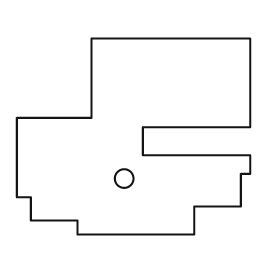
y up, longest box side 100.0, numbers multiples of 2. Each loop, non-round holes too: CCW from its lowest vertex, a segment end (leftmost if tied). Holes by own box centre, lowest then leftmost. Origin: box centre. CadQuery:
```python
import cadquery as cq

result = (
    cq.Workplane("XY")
    .moveTo(-24.0, -42.0)
    .lineTo(26.0, -42.0)
    .lineTo(26.0, -30.0)
    .lineTo(46.0, -30.0)
    .lineTo(46.0, -16.0)
    .lineTo(50.0, -16.0)
    .lineTo(50.0, -8.0)
    .lineTo(4.0, -8.0)
    .lineTo(4.0, 4.0)
    .lineTo(50.0, 4.0)
    .lineTo(50.0, 42.0)
    .lineTo(-18.0, 42.0)
    .lineTo(-18.0, 8.0)
    .lineTo(-50.0, 8.0)
    .lineTo(-50.0, -26.0)
    .lineTo(-44.0, -26.0)
    .lineTo(-44.0, -36.0)
    .lineTo(-24.0, -36.0)
    .close()
    .moveTo(-4.0, -18.0)
    .circle(4.0)
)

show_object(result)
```